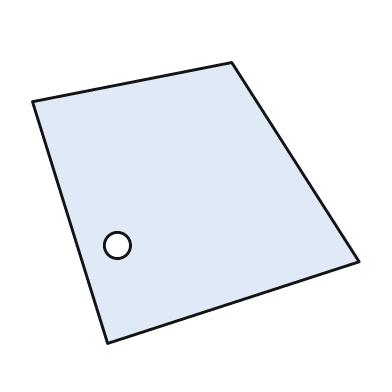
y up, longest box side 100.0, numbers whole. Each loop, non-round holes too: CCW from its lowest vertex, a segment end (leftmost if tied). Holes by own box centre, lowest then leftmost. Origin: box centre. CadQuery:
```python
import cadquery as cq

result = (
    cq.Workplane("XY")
    .moveTo(-27.0, -43.0)
    .lineTo(50.0, -18.0)
    .lineTo(11.0, 43.0)
    .lineTo(-50.0, 31.0)
    .close()
    .moveTo(-24.0, -13.0)
    .circle(4.0)
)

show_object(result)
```